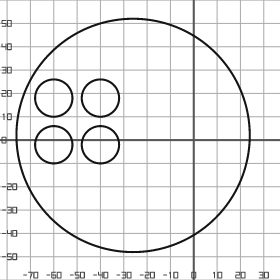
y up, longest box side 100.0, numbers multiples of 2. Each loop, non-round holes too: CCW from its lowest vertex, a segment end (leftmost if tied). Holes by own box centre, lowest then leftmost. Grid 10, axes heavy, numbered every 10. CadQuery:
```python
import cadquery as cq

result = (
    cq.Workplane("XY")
    .moveTo(-26.0, 2.0)
    .circle(50.0)
    .moveTo(-60.0, -2.0)
    .circle(8.0)
    .moveTo(-40.0, -2.0)
    .circle(8.0)
    .moveTo(-60.0, 18.0)
    .circle(8.0)
    .moveTo(-40.0, 18.0)
    .circle(8.0)
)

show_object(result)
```